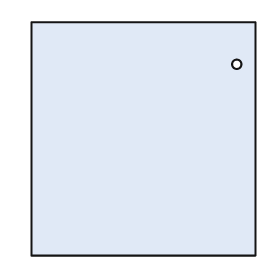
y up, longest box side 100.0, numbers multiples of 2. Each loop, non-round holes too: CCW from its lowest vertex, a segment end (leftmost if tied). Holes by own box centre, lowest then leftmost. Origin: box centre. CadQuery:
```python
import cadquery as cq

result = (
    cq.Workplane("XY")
    .moveTo(-48.0, -50.0)
    .lineTo(48.0, -50.0)
    .lineTo(48.0, 50.0)
    .lineTo(-48.0, 50.0)
    .close()
    .moveTo(40.0, 32.0)
    .circle(2.0)
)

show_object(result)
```